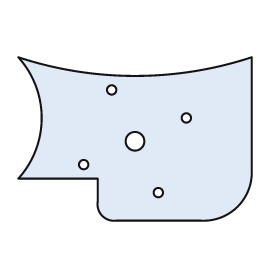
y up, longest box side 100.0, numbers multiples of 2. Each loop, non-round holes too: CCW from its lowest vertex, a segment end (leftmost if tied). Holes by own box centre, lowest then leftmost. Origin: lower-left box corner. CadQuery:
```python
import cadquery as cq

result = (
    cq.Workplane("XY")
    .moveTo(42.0, 0.0)
    .lineTo(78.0, 0.0)
    .threePointArc((94.0, 6.0), (100.0, 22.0))
    .lineTo(100.0, 70.0)
    .threePointArc((50.0, 62.0), (0.0, 70.0))
    .threePointArc((10.0, 44.0), (0.0, 18.0))
    .lineTo(34.0, 18.0)
    .lineTo(34.0, 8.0)
    .threePointArc((36.0, 2.0), (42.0, 0.0))
    .close()
    .moveTo(60.0, 12.0)
    .circle(2.0)
    .moveTo(28.0, 24.0)
    .circle(2.0)
    .moveTo(50.0, 34.0)
    .circle(4.0)
    .moveTo(72.0, 44.0)
    .circle(2.0)
    .moveTo(40.0, 56.0)
    .circle(2.0)
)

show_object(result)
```